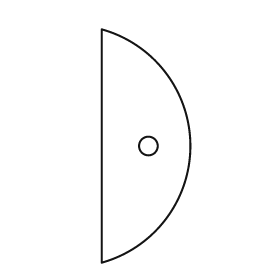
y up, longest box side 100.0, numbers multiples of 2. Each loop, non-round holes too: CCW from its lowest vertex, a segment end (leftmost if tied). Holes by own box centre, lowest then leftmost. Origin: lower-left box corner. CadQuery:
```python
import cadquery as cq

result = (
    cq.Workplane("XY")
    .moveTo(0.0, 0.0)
    .threePointArc((38.0, 50.0), (0.0, 100.0))
    .close()
    .moveTo(20.0, 50.0)
    .circle(4.0)
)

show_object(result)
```